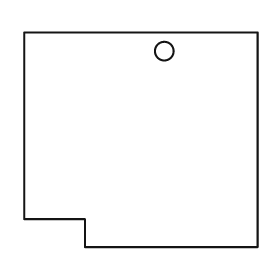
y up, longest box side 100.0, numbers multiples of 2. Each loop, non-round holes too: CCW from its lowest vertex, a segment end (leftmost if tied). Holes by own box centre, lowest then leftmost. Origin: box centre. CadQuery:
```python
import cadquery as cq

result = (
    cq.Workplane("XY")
    .moveTo(-24.0, -46.0)
    .lineTo(50.0, -46.0)
    .lineTo(50.0, 46.0)
    .lineTo(-50.0, 46.0)
    .lineTo(-50.0, -34.0)
    .lineTo(-24.0, -34.0)
    .close()
    .moveTo(10.0, 38.0)
    .circle(4.0)
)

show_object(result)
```